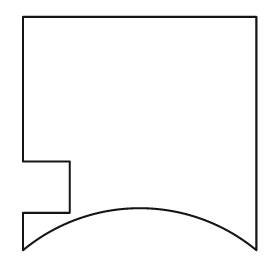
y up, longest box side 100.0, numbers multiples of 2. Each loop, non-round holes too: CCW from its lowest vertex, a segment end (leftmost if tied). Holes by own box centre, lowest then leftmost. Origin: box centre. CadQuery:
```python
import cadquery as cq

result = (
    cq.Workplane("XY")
    .moveTo(-50.0, -50.0)
    .threePointArc((0.0, -32.0), (50.0, -50.0))
    .lineTo(50.0, 50.0)
    .lineTo(-50.0, 50.0)
    .lineTo(-50.0, -12.0)
    .lineTo(-30.0, -12.0)
    .lineTo(-30.0, -34.0)
    .lineTo(-50.0, -34.0)
    .close()
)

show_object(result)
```